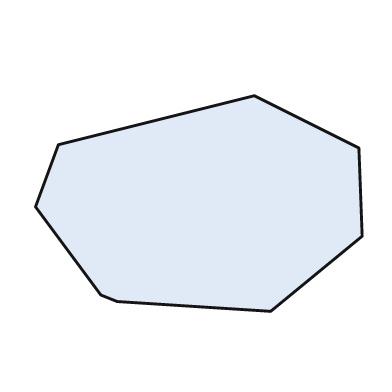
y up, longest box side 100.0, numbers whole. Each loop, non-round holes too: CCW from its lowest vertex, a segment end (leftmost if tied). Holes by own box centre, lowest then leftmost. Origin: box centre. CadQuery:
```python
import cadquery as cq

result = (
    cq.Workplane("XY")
    .moveTo(22.0, -33.0)
    .lineTo(50.0, -10.0)
    .lineTo(49.0, 17.0)
    .lineTo(17.0, 33.0)
    .lineTo(-43.0, 18.0)
    .lineTo(-50.0, -1.0)
    .lineTo(-30.0, -28.0)
    .lineTo(-25.0, -30.0)
    .close()
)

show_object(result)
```